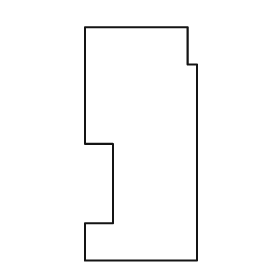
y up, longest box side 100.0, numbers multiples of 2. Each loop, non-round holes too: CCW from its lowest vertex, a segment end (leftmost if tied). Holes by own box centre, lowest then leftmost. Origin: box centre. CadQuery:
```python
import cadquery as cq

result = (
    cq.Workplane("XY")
    .moveTo(-24.0, -50.0)
    .lineTo(24.0, -50.0)
    .lineTo(24.0, 34.0)
    .lineTo(20.0, 34.0)
    .lineTo(20.0, 50.0)
    .lineTo(-24.0, 50.0)
    .lineTo(-24.0, 0.0)
    .lineTo(-12.0, 0.0)
    .lineTo(-12.0, -34.0)
    .lineTo(-24.0, -34.0)
    .close()
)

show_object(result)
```